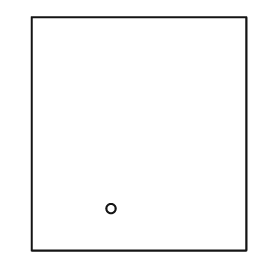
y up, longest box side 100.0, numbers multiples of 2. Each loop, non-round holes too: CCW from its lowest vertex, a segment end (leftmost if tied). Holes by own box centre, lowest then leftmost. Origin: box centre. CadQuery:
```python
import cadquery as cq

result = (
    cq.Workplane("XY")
    .moveTo(-46.0, -50.0)
    .lineTo(46.0, -50.0)
    .lineTo(46.0, 50.0)
    .lineTo(-46.0, 50.0)
    .close()
    .moveTo(-12.0, -32.0)
    .circle(2.0)
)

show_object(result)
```